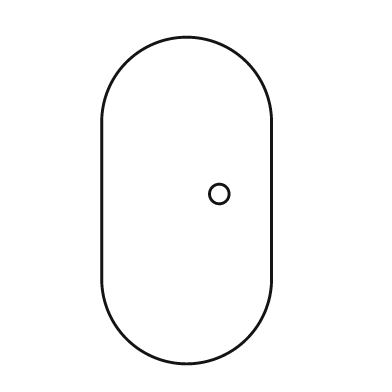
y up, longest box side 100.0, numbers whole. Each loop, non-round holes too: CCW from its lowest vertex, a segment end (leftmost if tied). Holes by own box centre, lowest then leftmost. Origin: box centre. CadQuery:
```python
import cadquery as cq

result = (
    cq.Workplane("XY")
    .moveTo(-26.0, -24.0)
    .threePointArc((0.0, -50.0), (26.0, -24.0))
    .lineTo(26.0, 24.0)
    .threePointArc((0.0, 50.0), (-26.0, 24.0))
    .close()
    .moveTo(10.0, 2.0)
    .circle(3.0)
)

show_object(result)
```